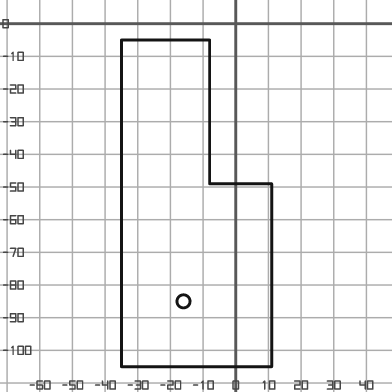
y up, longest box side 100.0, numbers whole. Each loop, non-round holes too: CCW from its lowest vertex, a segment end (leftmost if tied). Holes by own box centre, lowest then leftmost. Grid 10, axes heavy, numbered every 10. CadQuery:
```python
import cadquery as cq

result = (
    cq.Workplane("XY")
    .moveTo(-35.0, -105.0)
    .lineTo(11.0, -105.0)
    .lineTo(11.0, -49.0)
    .lineTo(-8.0, -49.0)
    .lineTo(-8.0, -5.0)
    .lineTo(-35.0, -5.0)
    .close()
    .moveTo(-16.0, -85.0)
    .circle(2.0)
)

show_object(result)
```